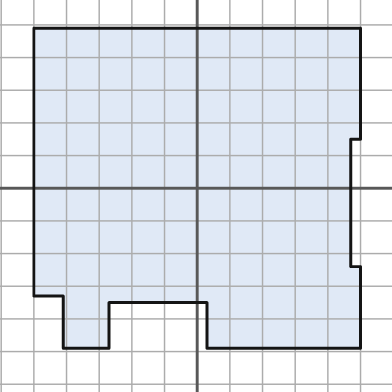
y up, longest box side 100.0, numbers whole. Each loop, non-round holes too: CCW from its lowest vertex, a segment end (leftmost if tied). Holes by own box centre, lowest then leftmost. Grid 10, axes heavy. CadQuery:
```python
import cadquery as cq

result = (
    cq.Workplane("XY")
    .moveTo(-41.0, -49.0)
    .lineTo(-27.0, -49.0)
    .lineTo(-27.0, -35.0)
    .lineTo(3.0, -35.0)
    .lineTo(3.0, -49.0)
    .lineTo(50.0, -49.0)
    .lineTo(50.0, -24.0)
    .lineTo(47.0, -24.0)
    .lineTo(47.0, 15.0)
    .lineTo(50.0, 15.0)
    .lineTo(50.0, 49.0)
    .lineTo(-50.0, 49.0)
    .lineTo(-50.0, -33.0)
    .lineTo(-41.0, -33.0)
    .close()
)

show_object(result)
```